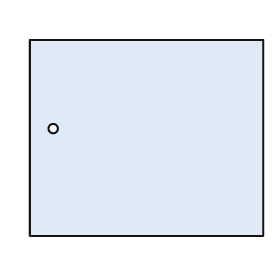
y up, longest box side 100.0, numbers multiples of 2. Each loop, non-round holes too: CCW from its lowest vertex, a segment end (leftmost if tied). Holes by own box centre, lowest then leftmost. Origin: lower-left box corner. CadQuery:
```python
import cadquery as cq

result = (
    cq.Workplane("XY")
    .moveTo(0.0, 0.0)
    .lineTo(100.0, 0.0)
    .lineTo(100.0, 84.0)
    .lineTo(0.0, 84.0)
    .close()
    .moveTo(10.0, 46.0)
    .circle(2.0)
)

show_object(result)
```